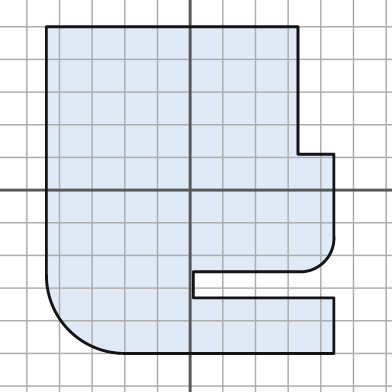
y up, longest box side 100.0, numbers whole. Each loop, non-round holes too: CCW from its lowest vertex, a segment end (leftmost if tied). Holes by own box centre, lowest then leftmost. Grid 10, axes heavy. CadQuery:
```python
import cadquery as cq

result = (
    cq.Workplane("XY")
    .moveTo(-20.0, -50.0)
    .lineTo(44.0, -50.0)
    .lineTo(44.0, -33.0)
    .lineTo(1.0, -33.0)
    .lineTo(1.0, -25.0)
    .lineTo(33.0, -25.0)
    .threePointArc((41.0, -22.0), (44.0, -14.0))
    .lineTo(44.0, 11.0)
    .lineTo(33.0, 11.0)
    .lineTo(33.0, 50.0)
    .lineTo(-44.0, 50.0)
    .lineTo(-44.0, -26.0)
    .threePointArc((-37.0, -43.0), (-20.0, -50.0))
    .close()
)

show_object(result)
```